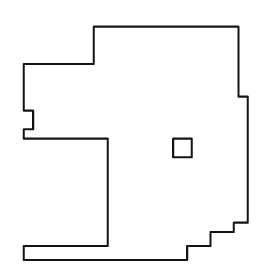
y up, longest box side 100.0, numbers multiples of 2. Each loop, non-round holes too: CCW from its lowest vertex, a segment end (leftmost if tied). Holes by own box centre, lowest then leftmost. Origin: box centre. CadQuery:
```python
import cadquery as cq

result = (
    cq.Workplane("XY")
    .moveTo(-48.0, -50.0)
    .lineTo(22.0, -50.0)
    .lineTo(22.0, -44.0)
    .lineTo(32.0, -44.0)
    .lineTo(32.0, -38.0)
    .lineTo(42.0, -38.0)
    .lineTo(42.0, -34.0)
    .lineTo(48.0, -34.0)
    .lineTo(48.0, 20.0)
    .lineTo(44.0, 20.0)
    .lineTo(44.0, 50.0)
    .lineTo(-18.0, 50.0)
    .lineTo(-18.0, 34.0)
    .lineTo(-48.0, 34.0)
    .lineTo(-48.0, 14.0)
    .lineTo(-44.0, 14.0)
    .lineTo(-44.0, 6.0)
    .lineTo(-48.0, 6.0)
    .lineTo(-48.0, 2.0)
    .lineTo(-12.0, 2.0)
    .lineTo(-12.0, -44.0)
    .lineTo(-48.0, -44.0)
    .close()
    .moveTo(16.0, -6.0)
    .lineTo(24.0, -6.0)
    .lineTo(24.0, 2.0)
    .lineTo(16.0, 2.0)
    .close()
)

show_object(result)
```